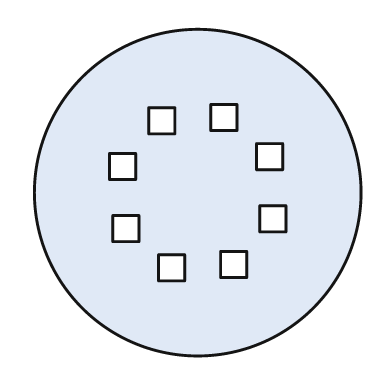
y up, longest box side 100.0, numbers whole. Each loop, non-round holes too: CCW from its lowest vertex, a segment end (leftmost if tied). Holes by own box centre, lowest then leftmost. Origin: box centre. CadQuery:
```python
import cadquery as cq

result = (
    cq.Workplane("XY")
    .moveTo(0.0, 0.0)
    .circle(50.0)
    .moveTo(-12.0, -27.0)
    .lineTo(-4.0, -27.0)
    .lineTo(-4.0, -19.0)
    .lineTo(-12.0, -19.0)
    .close()
    .moveTo(7.0, -26.0)
    .lineTo(15.0, -26.0)
    .lineTo(15.0, -18.0)
    .lineTo(7.0, -18.0)
    .close()
    .moveTo(-26.0, -15.0)
    .lineTo(-18.0, -15.0)
    .lineTo(-18.0, -7.0)
    .lineTo(-26.0, -7.0)
    .close()
    .moveTo(19.0, -12.0)
    .lineTo(27.0, -12.0)
    .lineTo(27.0, -4.0)
    .lineTo(19.0, -4.0)
    .close()
    .moveTo(-27.0, 4.0)
    .lineTo(-19.0, 4.0)
    .lineTo(-19.0, 12.0)
    .lineTo(-27.0, 12.0)
    .close()
    .moveTo(18.0, 7.0)
    .lineTo(26.0, 7.0)
    .lineTo(26.0, 15.0)
    .lineTo(18.0, 15.0)
    .close()
    .moveTo(-15.0, 18.0)
    .lineTo(-7.0, 18.0)
    .lineTo(-7.0, 26.0)
    .lineTo(-15.0, 26.0)
    .close()
    .moveTo(4.0, 19.0)
    .lineTo(12.0, 19.0)
    .lineTo(12.0, 27.0)
    .lineTo(4.0, 27.0)
    .close()
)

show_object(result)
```